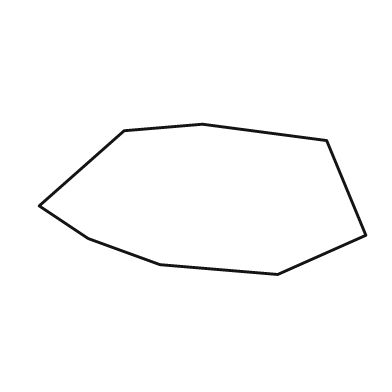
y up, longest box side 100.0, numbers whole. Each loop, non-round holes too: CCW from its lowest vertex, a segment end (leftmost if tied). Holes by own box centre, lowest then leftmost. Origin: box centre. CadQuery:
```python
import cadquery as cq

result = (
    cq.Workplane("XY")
    .moveTo(23.0, -23.0)
    .lineTo(50.0, -11.0)
    .lineTo(38.0, 18.0)
    .lineTo(0.0, 23.0)
    .lineTo(-24.0, 21.0)
    .lineTo(-50.0, -2.0)
    .lineTo(-35.0, -12.0)
    .lineTo(-13.0, -20.0)
    .close()
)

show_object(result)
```